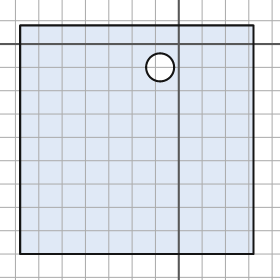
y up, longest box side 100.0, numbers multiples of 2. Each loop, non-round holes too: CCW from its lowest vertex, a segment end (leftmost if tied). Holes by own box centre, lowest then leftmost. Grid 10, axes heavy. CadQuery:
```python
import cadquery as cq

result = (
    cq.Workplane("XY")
    .moveTo(-68.0, -90.0)
    .lineTo(32.0, -90.0)
    .lineTo(32.0, 8.0)
    .lineTo(-68.0, 8.0)
    .close()
    .moveTo(-8.0, -10.0)
    .circle(6.0)
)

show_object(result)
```